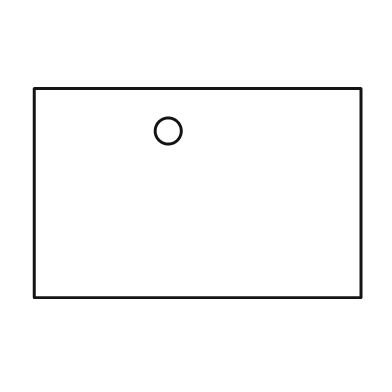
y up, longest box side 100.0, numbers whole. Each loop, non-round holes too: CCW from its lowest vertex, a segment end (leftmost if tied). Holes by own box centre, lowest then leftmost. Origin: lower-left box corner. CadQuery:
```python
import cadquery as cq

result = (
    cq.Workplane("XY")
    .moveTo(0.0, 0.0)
    .lineTo(100.0, 0.0)
    .lineTo(100.0, 64.0)
    .lineTo(0.0, 64.0)
    .close()
    .moveTo(41.0, 51.0)
    .circle(4.0)
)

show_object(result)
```